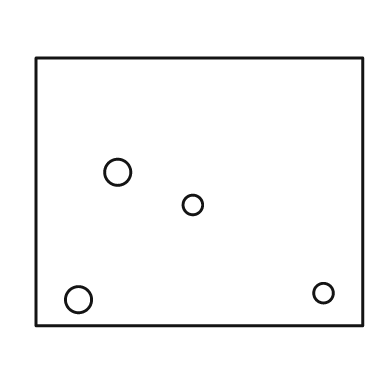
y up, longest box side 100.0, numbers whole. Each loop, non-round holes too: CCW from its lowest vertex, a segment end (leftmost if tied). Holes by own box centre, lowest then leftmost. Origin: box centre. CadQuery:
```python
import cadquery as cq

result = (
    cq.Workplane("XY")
    .moveTo(-50.0, -41.0)
    .lineTo(50.0, -41.0)
    .lineTo(50.0, 41.0)
    .lineTo(-50.0, 41.0)
    .close()
    .moveTo(-37.0, -33.0)
    .circle(4.0)
    .moveTo(38.0, -31.0)
    .circle(3.0)
    .moveTo(-2.0, -4.0)
    .circle(3.0)
    .moveTo(-25.0, 6.0)
    .circle(4.0)
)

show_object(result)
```